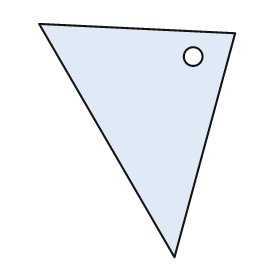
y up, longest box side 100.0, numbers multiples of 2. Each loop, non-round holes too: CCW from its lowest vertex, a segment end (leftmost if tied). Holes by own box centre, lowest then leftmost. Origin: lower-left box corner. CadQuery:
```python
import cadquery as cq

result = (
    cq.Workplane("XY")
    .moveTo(58.0, 0.0)
    .lineTo(84.0, 96.0)
    .lineTo(0.0, 100.0)
    .close()
    .moveTo(66.0, 86.0)
    .circle(4.0)
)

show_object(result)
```